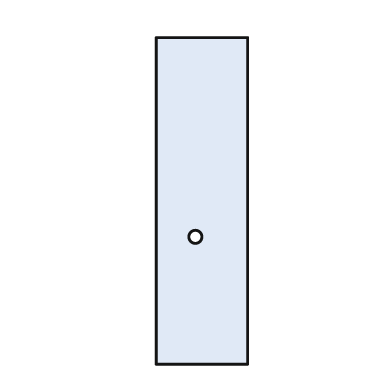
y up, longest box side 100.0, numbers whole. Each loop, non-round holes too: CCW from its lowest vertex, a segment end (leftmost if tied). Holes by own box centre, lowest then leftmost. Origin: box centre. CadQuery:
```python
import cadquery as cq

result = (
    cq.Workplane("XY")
    .moveTo(-14.0, -50.0)
    .lineTo(14.0, -50.0)
    .lineTo(14.0, 50.0)
    .lineTo(-14.0, 50.0)
    .close()
    .moveTo(-2.0, -11.0)
    .circle(2.0)
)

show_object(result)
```